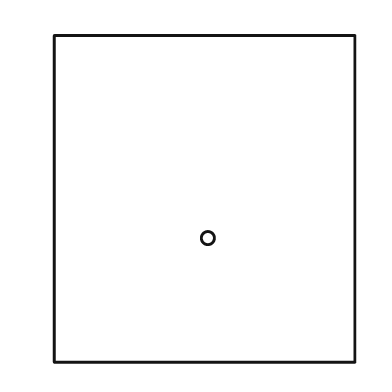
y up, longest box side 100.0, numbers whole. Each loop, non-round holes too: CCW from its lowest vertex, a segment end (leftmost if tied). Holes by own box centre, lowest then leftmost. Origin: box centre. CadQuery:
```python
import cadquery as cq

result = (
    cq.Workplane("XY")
    .moveTo(-46.0, -50.0)
    .lineTo(46.0, -50.0)
    .lineTo(46.0, 50.0)
    .lineTo(-46.0, 50.0)
    .close()
    .moveTo(1.0, -12.0)
    .circle(2.0)
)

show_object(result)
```